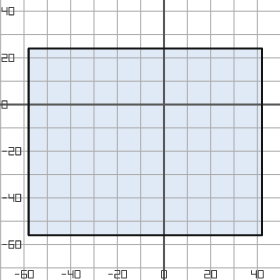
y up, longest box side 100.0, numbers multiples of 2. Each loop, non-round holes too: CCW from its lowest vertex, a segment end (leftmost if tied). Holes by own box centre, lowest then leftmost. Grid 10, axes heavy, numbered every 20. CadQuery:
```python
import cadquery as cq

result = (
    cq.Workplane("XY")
    .moveTo(-58.0, -56.0)
    .lineTo(42.0, -56.0)
    .lineTo(42.0, 24.0)
    .lineTo(-58.0, 24.0)
    .close()
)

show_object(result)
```